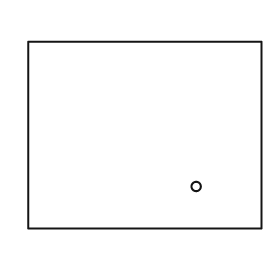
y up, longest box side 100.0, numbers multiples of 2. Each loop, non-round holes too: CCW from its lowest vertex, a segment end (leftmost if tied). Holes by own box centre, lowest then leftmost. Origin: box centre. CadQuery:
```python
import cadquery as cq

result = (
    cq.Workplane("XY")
    .moveTo(-50.0, -40.0)
    .lineTo(50.0, -40.0)
    .lineTo(50.0, 40.0)
    .lineTo(-50.0, 40.0)
    .close()
    .moveTo(22.0, -22.0)
    .circle(2.0)
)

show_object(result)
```